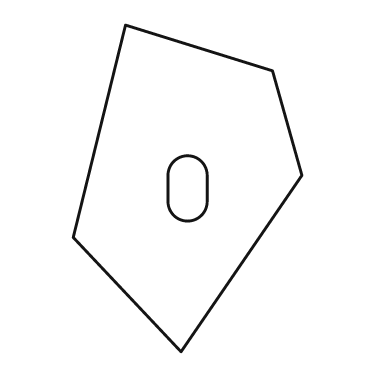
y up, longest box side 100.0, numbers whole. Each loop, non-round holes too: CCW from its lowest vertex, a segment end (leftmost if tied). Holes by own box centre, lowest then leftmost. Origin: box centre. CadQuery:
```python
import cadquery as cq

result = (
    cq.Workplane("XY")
    .moveTo(-2.0, -50.0)
    .lineTo(35.0, 4.0)
    .lineTo(26.0, 36.0)
    .lineTo(-19.0, 50.0)
    .lineTo(-35.0, -15.0)
    .close()
    .moveTo(-6.0, -4.0)
    .threePointArc((0.0, -10.0), (6.0, -4.0))
    .lineTo(6.0, 4.0)
    .threePointArc((0.0, 10.0), (-6.0, 4.0))
    .close()
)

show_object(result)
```